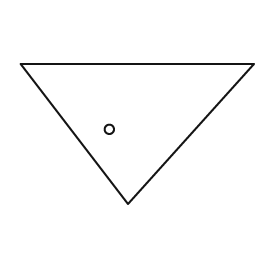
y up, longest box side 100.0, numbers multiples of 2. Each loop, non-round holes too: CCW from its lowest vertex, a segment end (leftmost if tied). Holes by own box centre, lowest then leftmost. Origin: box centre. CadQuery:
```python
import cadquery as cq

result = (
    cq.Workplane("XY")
    .moveTo(-4.0, -30.0)
    .lineTo(50.0, 30.0)
    .lineTo(-50.0, 30.0)
    .close()
    .moveTo(-12.0, 2.0)
    .circle(2.0)
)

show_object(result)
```